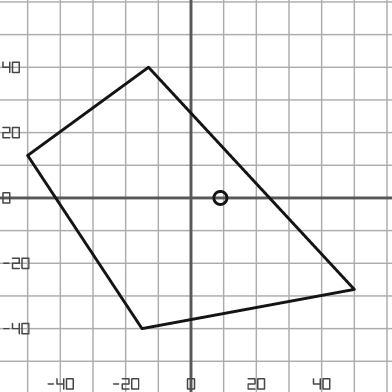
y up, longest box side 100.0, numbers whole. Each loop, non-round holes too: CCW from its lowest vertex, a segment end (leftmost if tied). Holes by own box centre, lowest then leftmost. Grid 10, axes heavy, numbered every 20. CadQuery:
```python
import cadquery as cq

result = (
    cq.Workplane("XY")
    .moveTo(-15.0, -40.0)
    .lineTo(50.0, -28.0)
    .lineTo(-13.0, 40.0)
    .lineTo(-50.0, 13.0)
    .close()
    .moveTo(9.0, 0.0)
    .circle(2.0)
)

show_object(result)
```